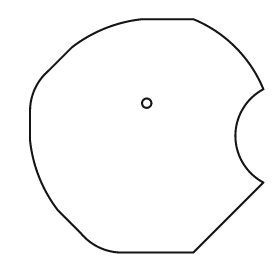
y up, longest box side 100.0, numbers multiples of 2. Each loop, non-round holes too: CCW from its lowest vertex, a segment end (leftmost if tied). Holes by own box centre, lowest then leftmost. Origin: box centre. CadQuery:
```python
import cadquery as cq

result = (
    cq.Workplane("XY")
    .moveTo(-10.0, -50.0)
    .lineTo(20.0, -50.0)
    .lineTo(50.0, -20.0)
    .threePointArc((38.0, 0.0), (50.0, 20.0))
    .threePointArc((38.0, 38.0), (20.0, 50.0))
    .lineTo(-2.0, 50.0)
    .threePointArc((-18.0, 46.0), (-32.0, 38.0))
    .lineTo(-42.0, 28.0)
    .threePointArc((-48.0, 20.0), (-50.0, 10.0))
    .lineTo(-50.0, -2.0)
    .threePointArc((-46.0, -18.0), (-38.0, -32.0))
    .lineTo(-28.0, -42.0)
    .threePointArc((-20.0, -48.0), (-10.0, -50.0))
    .close()
    .moveTo(0.0, 14.0)
    .circle(2.0)
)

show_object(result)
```